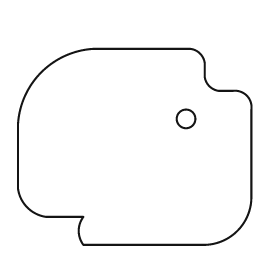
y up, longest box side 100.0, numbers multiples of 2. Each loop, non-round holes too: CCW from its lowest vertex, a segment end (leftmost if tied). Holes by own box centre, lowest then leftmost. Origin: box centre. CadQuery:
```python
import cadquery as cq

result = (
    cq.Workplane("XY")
    .moveTo(-22.0, -42.0)
    .lineTo(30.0, -42.0)
    .threePointArc((44.0, -36.0), (50.0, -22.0))
    .lineTo(50.0, 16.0)
    .threePointArc((48.0, 22.0), (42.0, 24.0))
    .lineTo(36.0, 24.0)
    .threePointArc((32.0, 26.0), (30.0, 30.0))
    .lineTo(30.0, 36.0)
    .threePointArc((28.0, 40.0), (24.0, 42.0))
    .lineTo(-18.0, 42.0)
    .threePointArc((-40.0, 32.0), (-50.0, 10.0))
    .lineTo(-50.0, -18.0)
    .threePointArc((-46.0, -26.0), (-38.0, -30.0))
    .lineTo(-22.0, -30.0)
    .threePointArc((-24.0, -36.0), (-22.0, -42.0))
    .close()
    .moveTo(22.0, 12.0)
    .circle(4.0)
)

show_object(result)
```